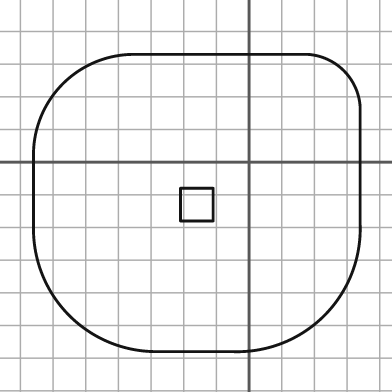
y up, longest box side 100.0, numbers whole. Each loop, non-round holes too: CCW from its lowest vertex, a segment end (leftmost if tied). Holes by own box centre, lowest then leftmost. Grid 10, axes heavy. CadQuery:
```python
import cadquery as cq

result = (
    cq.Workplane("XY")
    .moveTo(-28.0, -58.0)
    .lineTo(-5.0, -58.0)
    .threePointArc((23.0, -47.0), (34.0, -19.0))
    .lineTo(34.0, 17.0)
    .threePointArc((29.0, 28.0), (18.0, 33.0))
    .lineTo(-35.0, 33.0)
    .threePointArc((-57.0, 24.0), (-66.0, 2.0))
    .lineTo(-66.0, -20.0)
    .threePointArc((-55.0, -47.0), (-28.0, -58.0))
    .close()
    .moveTo(-21.0, -18.0)
    .lineTo(-11.0, -18.0)
    .lineTo(-11.0, -8.0)
    .lineTo(-21.0, -8.0)
    .close()
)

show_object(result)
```